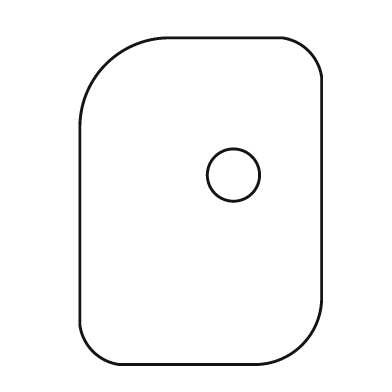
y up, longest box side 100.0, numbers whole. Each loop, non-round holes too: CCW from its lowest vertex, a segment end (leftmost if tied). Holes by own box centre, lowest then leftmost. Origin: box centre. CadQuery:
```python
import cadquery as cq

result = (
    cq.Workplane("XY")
    .moveTo(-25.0, -50.0)
    .lineTo(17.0, -50.0)
    .threePointArc((31.0, -44.0), (37.0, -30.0))
    .lineTo(37.0, 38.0)
    .threePointArc((33.0, 46.0), (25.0, 50.0))
    .lineTo(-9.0, 50.0)
    .threePointArc((-29.0, 42.0), (-37.0, 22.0))
    .lineTo(-37.0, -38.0)
    .threePointArc((-33.0, -46.0), (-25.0, -50.0))
    .close()
    .moveTo(10.0, 8.0)
    .circle(8.0)
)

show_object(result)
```